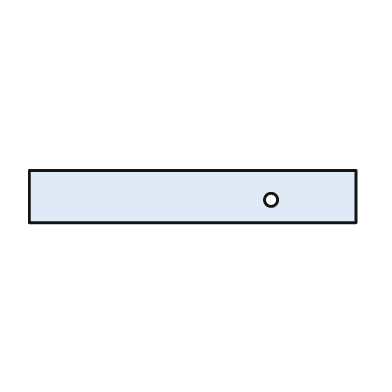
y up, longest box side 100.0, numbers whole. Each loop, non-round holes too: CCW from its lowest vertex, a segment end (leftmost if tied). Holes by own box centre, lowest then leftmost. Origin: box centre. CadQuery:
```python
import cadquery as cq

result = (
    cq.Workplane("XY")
    .moveTo(-50.0, -8.0)
    .lineTo(50.0, -8.0)
    .lineTo(50.0, 8.0)
    .lineTo(-50.0, 8.0)
    .close()
    .moveTo(24.0, -1.0)
    .circle(2.0)
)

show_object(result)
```